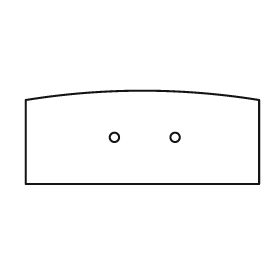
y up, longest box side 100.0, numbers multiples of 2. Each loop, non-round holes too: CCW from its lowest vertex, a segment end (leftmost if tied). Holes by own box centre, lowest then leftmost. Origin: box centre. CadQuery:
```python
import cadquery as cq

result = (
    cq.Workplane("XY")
    .moveTo(-50.0, -20.0)
    .lineTo(50.0, -20.0)
    .lineTo(50.0, 16.0)
    .threePointArc((0.0, 20.0), (-50.0, 16.0))
    .close()
    .moveTo(-12.0, 0.0)
    .circle(2.0)
    .moveTo(14.0, 0.0)
    .circle(2.0)
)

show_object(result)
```